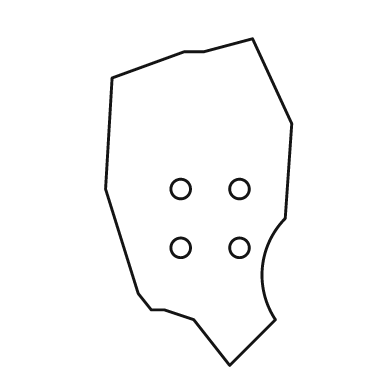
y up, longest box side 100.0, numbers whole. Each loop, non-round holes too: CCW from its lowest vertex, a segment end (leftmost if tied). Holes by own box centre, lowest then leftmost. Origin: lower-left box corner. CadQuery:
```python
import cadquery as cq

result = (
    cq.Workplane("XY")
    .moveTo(38.0, 0.0)
    .lineTo(52.0, 14.0)
    .threePointArc((48.0, 30.0), (55.0, 45.0))
    .lineTo(57.0, 74.0)
    .lineTo(45.0, 100.0)
    .lineTo(30.0, 96.0)
    .lineTo(24.0, 96.0)
    .lineTo(2.0, 88.0)
    .lineTo(0.0, 54.0)
    .lineTo(10.0, 22.0)
    .lineTo(14.0, 17.0)
    .lineTo(18.0, 17.0)
    .lineTo(27.0, 14.0)
    .close()
    .moveTo(23.0, 36.0)
    .circle(3.0)
    .moveTo(41.0, 36.0)
    .circle(3.0)
    .moveTo(23.0, 54.0)
    .circle(3.0)
    .moveTo(41.0, 54.0)
    .circle(3.0)
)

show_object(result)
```